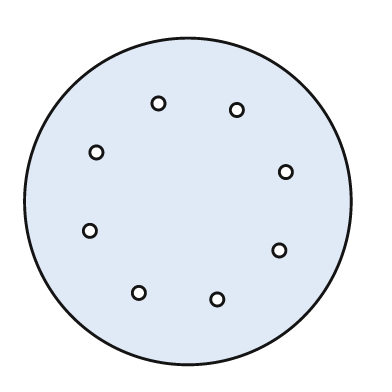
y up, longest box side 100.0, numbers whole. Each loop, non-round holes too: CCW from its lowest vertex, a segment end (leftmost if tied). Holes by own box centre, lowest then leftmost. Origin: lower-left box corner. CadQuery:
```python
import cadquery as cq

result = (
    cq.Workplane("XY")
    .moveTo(50.0, 50.0)
    .circle(50.0)
    .moveTo(59.0, 20.0)
    .circle(2.0)
    .moveTo(35.0, 22.0)
    .circle(2.0)
    .moveTo(78.0, 35.0)
    .circle(2.0)
    .moveTo(20.0, 41.0)
    .circle(2.0)
    .moveTo(80.0, 59.0)
    .circle(2.0)
    .moveTo(22.0, 65.0)
    .circle(2.0)
    .moveTo(65.0, 78.0)
    .circle(2.0)
    .moveTo(41.0, 80.0)
    .circle(2.0)
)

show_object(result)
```